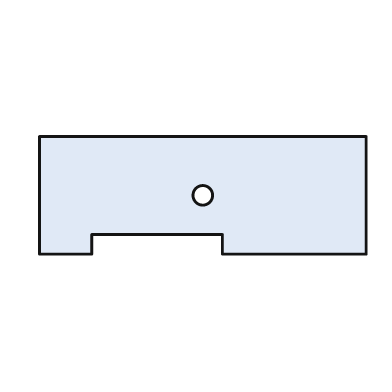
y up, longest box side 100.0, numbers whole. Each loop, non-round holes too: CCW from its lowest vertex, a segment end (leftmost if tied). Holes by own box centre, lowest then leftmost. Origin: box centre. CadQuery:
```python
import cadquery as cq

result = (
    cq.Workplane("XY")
    .moveTo(-50.0, -18.0)
    .lineTo(-34.0, -18.0)
    .lineTo(-34.0, -12.0)
    .lineTo(6.0, -12.0)
    .lineTo(6.0, -18.0)
    .lineTo(50.0, -18.0)
    .lineTo(50.0, 18.0)
    .lineTo(-50.0, 18.0)
    .close()
    .moveTo(0.0, 0.0)
    .circle(3.0)
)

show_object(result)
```